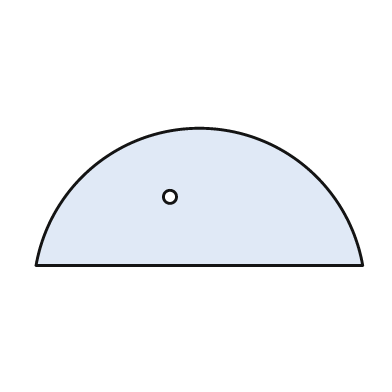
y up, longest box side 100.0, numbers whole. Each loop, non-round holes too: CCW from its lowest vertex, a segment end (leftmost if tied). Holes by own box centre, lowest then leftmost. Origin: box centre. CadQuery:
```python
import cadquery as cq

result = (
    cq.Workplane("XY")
    .moveTo(-50.0, -21.0)
    .lineTo(50.0, -21.0)
    .threePointArc((0.0, 21.0), (-50.0, -21.0))
    .close()
    .moveTo(-9.0, 0.0)
    .circle(2.0)
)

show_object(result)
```